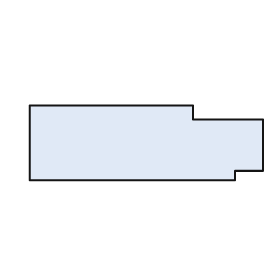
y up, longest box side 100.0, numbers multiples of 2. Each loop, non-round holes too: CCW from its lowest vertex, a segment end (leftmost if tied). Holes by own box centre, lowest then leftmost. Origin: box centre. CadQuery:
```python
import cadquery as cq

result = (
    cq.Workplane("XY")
    .moveTo(-50.0, -16.0)
    .lineTo(38.0, -16.0)
    .lineTo(38.0, -12.0)
    .lineTo(50.0, -12.0)
    .lineTo(50.0, 10.0)
    .lineTo(20.0, 10.0)
    .lineTo(20.0, 16.0)
    .lineTo(-50.0, 16.0)
    .close()
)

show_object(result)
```